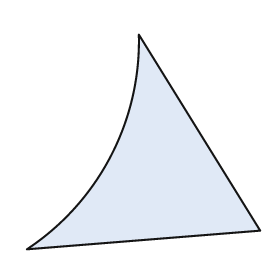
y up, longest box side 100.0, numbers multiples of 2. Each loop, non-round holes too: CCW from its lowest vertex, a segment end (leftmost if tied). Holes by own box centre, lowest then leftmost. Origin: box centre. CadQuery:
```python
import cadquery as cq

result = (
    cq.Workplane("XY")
    .moveTo(-50.0, -46.0)
    .lineTo(50.0, -38.0)
    .lineTo(-2.0, 46.0)
    .threePointArc((-14.0, -6.0), (-50.0, -46.0))
    .close()
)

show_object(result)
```